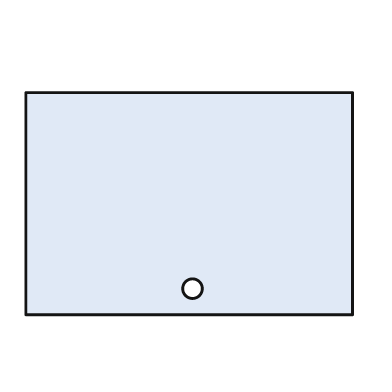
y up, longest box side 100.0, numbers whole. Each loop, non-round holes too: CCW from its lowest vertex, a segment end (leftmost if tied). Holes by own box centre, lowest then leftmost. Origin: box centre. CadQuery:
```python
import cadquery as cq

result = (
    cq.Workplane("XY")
    .moveTo(-50.0, -34.0)
    .lineTo(50.0, -34.0)
    .lineTo(50.0, 34.0)
    .lineTo(-50.0, 34.0)
    .close()
    .moveTo(1.0, -26.0)
    .circle(3.0)
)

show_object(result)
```